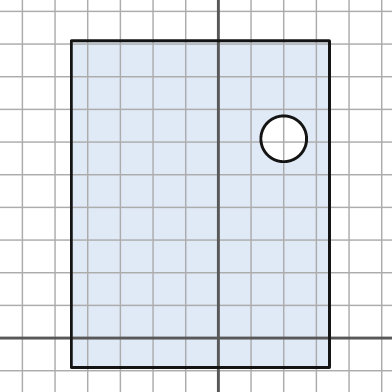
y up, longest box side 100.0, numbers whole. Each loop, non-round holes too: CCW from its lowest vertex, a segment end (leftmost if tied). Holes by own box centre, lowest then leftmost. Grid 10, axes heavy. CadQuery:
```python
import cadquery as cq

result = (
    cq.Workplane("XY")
    .moveTo(-45.0, -9.0)
    .lineTo(34.0, -9.0)
    .lineTo(34.0, 91.0)
    .lineTo(-45.0, 91.0)
    .close()
    .moveTo(20.0, 61.0)
    .circle(7.0)
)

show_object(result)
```